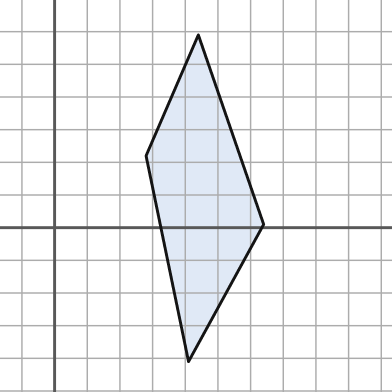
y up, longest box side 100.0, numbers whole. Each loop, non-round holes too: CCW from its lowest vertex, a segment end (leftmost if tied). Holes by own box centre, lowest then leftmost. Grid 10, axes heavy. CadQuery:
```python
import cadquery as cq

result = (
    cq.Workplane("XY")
    .moveTo(41.0, -41.0)
    .lineTo(64.0, 1.0)
    .lineTo(44.0, 59.0)
    .lineTo(28.0, 22.0)
    .close()
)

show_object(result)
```